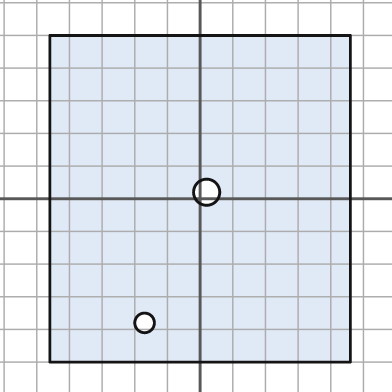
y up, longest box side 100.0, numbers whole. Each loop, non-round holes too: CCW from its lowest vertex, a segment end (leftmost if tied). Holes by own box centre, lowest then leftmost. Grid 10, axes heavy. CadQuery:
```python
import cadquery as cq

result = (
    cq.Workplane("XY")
    .moveTo(-46.0, -50.0)
    .lineTo(46.0, -50.0)
    .lineTo(46.0, 50.0)
    .lineTo(-46.0, 50.0)
    .close()
    .moveTo(-17.0, -38.0)
    .circle(3.0)
    .moveTo(2.0, 2.0)
    .circle(4.0)
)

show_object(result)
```